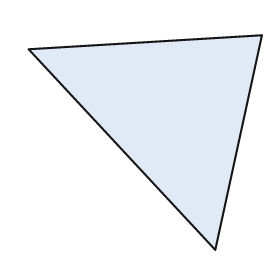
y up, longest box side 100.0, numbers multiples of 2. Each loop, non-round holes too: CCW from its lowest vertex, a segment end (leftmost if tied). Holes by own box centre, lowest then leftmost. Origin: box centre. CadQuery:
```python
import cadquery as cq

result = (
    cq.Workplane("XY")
    .moveTo(30.0, -46.0)
    .lineTo(50.0, 46.0)
    .lineTo(-50.0, 40.0)
    .close()
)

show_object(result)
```